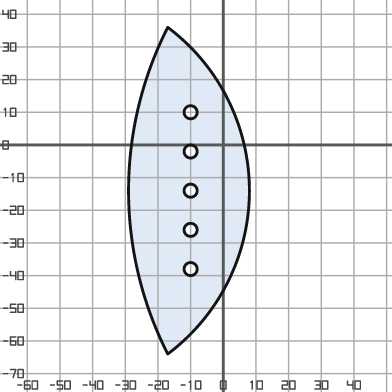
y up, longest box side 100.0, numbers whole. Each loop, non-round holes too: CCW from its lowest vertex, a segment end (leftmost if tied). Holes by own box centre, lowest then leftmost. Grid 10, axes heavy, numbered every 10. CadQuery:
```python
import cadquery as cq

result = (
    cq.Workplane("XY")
    .moveTo(-17.0, -64.0)
    .threePointArc((8.0, -14.0), (-17.0, 36.0))
    .threePointArc((-29.0, -14.0), (-17.0, -64.0))
    .close()
    .moveTo(-10.0, -38.0)
    .circle(2.0)
    .moveTo(-10.0, -26.0)
    .circle(2.0)
    .moveTo(-10.0, -14.0)
    .circle(2.0)
    .moveTo(-10.0, -2.0)
    .circle(2.0)
    .moveTo(-10.0, 10.0)
    .circle(2.0)
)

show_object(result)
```